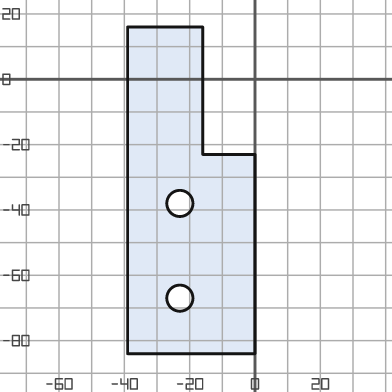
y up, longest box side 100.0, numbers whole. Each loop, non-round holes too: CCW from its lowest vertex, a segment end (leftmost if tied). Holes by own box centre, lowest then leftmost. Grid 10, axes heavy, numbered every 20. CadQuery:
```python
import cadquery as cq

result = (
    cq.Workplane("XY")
    .moveTo(-39.0, -84.0)
    .lineTo(0.0, -84.0)
    .lineTo(0.0, -23.0)
    .lineTo(-16.0, -23.0)
    .lineTo(-16.0, 16.0)
    .lineTo(-39.0, 16.0)
    .close()
    .moveTo(-23.0, -67.0)
    .circle(4.0)
    .moveTo(-23.0, -38.0)
    .circle(4.0)
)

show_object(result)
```